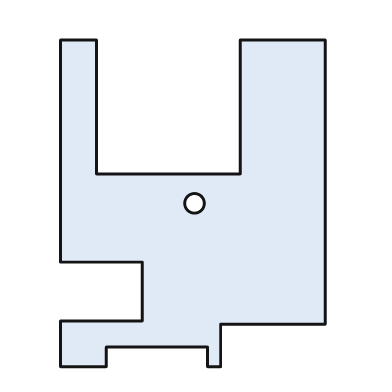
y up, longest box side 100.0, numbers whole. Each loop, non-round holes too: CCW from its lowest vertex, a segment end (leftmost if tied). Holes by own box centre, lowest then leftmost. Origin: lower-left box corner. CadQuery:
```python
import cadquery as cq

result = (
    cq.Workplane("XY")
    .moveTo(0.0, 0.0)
    .lineTo(14.0, 0.0)
    .lineTo(14.0, 6.0)
    .lineTo(45.0, 6.0)
    .lineTo(45.0, 0.0)
    .lineTo(49.0, 0.0)
    .lineTo(49.0, 13.0)
    .lineTo(81.0, 13.0)
    .lineTo(81.0, 100.0)
    .lineTo(55.0, 100.0)
    .lineTo(55.0, 59.0)
    .lineTo(11.0, 59.0)
    .lineTo(11.0, 100.0)
    .lineTo(0.0, 100.0)
    .lineTo(0.0, 32.0)
    .lineTo(25.0, 32.0)
    .lineTo(25.0, 14.0)
    .lineTo(0.0, 14.0)
    .close()
    .moveTo(41.0, 50.0)
    .circle(3.0)
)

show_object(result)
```